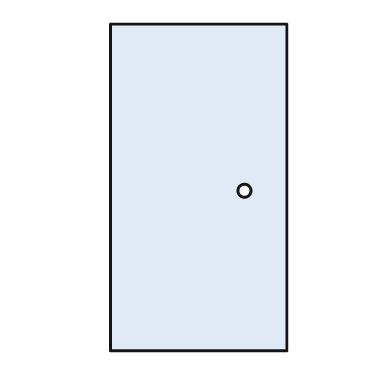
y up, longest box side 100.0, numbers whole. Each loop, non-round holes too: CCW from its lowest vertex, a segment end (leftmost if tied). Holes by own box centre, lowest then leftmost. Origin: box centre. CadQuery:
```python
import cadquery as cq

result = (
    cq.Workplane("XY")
    .moveTo(-27.0, -50.0)
    .lineTo(27.0, -50.0)
    .lineTo(27.0, 50.0)
    .lineTo(-27.0, 50.0)
    .close()
    .moveTo(14.0, -1.0)
    .circle(2.0)
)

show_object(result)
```